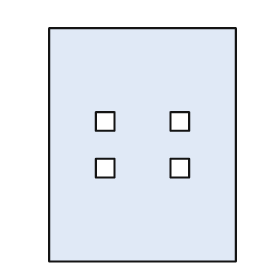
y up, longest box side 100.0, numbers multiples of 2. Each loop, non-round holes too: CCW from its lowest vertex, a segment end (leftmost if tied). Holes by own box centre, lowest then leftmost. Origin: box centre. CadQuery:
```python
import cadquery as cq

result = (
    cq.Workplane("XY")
    .moveTo(-40.0, -50.0)
    .lineTo(40.0, -50.0)
    .lineTo(40.0, 50.0)
    .lineTo(-40.0, 50.0)
    .close()
    .moveTo(-20.0, -14.0)
    .lineTo(-12.0, -14.0)
    .lineTo(-12.0, -6.0)
    .lineTo(-20.0, -6.0)
    .close()
    .moveTo(12.0, -14.0)
    .lineTo(20.0, -14.0)
    .lineTo(20.0, -6.0)
    .lineTo(12.0, -6.0)
    .close()
    .moveTo(-20.0, 6.0)
    .lineTo(-12.0, 6.0)
    .lineTo(-12.0, 14.0)
    .lineTo(-20.0, 14.0)
    .close()
    .moveTo(12.0, 6.0)
    .lineTo(20.0, 6.0)
    .lineTo(20.0, 14.0)
    .lineTo(12.0, 14.0)
    .close()
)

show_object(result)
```